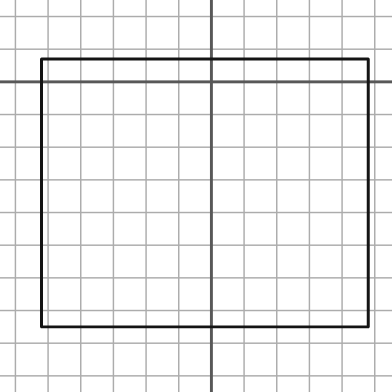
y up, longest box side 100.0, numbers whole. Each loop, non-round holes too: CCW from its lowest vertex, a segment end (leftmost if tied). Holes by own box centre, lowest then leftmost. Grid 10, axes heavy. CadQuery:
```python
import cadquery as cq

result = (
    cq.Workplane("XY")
    .moveTo(-52.0, -75.0)
    .lineTo(48.0, -75.0)
    .lineTo(48.0, 7.0)
    .lineTo(-52.0, 7.0)
    .close()
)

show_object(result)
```